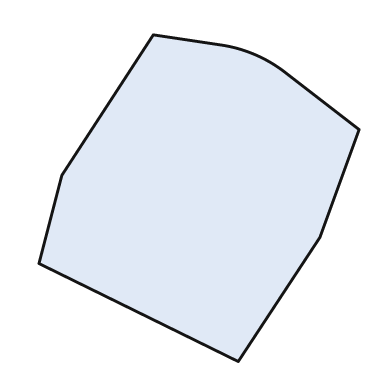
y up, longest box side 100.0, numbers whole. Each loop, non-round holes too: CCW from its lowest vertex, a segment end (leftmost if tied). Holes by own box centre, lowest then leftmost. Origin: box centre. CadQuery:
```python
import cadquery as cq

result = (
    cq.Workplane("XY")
    .moveTo(12.0, -50.0)
    .lineTo(37.0, -12.0)
    .lineTo(49.0, 21.0)
    .lineTo(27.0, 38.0)
    .threePointArc((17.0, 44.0), (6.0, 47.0))
    .lineTo(-14.0, 50.0)
    .lineTo(-42.0, 7.0)
    .lineTo(-49.0, -20.0)
    .close()
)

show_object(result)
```